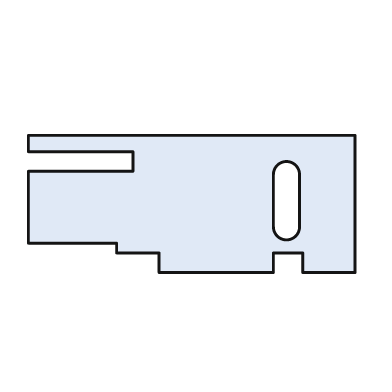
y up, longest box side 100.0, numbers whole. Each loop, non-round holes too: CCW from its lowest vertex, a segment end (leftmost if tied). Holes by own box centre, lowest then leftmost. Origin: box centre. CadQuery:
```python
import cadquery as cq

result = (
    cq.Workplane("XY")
    .moveTo(-10.0, -21.0)
    .lineTo(25.0, -21.0)
    .lineTo(25.0, -15.0)
    .lineTo(34.0, -15.0)
    .lineTo(34.0, -21.0)
    .lineTo(50.0, -21.0)
    .lineTo(50.0, 21.0)
    .lineTo(-50.0, 21.0)
    .lineTo(-50.0, 16.0)
    .lineTo(-18.0, 16.0)
    .lineTo(-18.0, 10.0)
    .lineTo(-50.0, 10.0)
    .lineTo(-50.0, -12.0)
    .lineTo(-23.0, -12.0)
    .lineTo(-23.0, -15.0)
    .lineTo(-10.0, -15.0)
    .close()
    .moveTo(25.0, -7.0)
    .threePointArc((29.0, -11.0), (33.0, -7.0))
    .lineTo(33.0, 9.0)
    .threePointArc((29.0, 13.0), (25.0, 9.0))
    .close()
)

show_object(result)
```